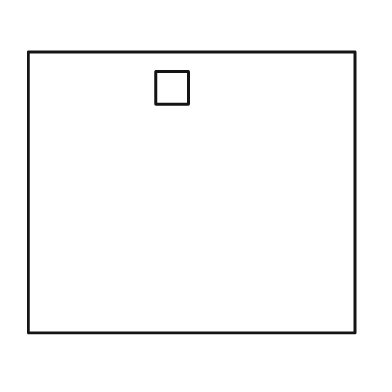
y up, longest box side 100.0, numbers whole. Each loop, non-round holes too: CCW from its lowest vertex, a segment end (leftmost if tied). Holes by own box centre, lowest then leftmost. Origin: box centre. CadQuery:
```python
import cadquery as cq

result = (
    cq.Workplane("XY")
    .moveTo(-50.0, -43.0)
    .lineTo(50.0, -43.0)
    .lineTo(50.0, 43.0)
    .lineTo(-50.0, 43.0)
    .close()
    .moveTo(-11.0, 27.0)
    .lineTo(-1.0, 27.0)
    .lineTo(-1.0, 37.0)
    .lineTo(-11.0, 37.0)
    .close()
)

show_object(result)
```